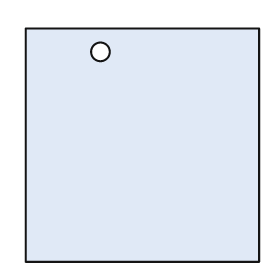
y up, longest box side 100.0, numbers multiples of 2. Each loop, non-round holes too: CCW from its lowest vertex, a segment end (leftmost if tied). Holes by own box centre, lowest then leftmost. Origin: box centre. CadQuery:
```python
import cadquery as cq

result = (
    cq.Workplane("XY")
    .moveTo(-50.0, -50.0)
    .lineTo(50.0, -50.0)
    .lineTo(50.0, 50.0)
    .lineTo(-50.0, 50.0)
    .close()
    .moveTo(-18.0, 40.0)
    .circle(4.0)
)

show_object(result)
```